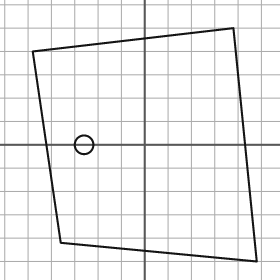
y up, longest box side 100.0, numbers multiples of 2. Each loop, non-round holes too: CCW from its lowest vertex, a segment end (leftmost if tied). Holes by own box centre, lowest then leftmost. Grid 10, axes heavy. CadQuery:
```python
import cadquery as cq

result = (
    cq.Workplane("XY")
    .moveTo(48.0, -50.0)
    .lineTo(38.0, 50.0)
    .lineTo(-48.0, 40.0)
    .lineTo(-36.0, -42.0)
    .close()
    .moveTo(-26.0, 0.0)
    .circle(4.0)
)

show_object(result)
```